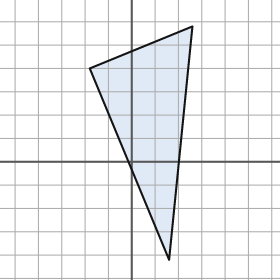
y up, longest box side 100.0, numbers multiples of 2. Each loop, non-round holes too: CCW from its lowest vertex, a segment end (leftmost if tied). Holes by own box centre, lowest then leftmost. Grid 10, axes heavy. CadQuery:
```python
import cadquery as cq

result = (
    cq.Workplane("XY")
    .moveTo(16.0, -42.0)
    .lineTo(26.0, 58.0)
    .lineTo(-18.0, 40.0)
    .close()
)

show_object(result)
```